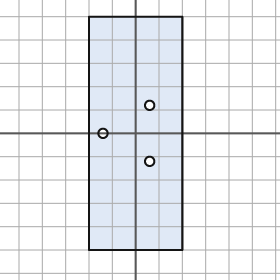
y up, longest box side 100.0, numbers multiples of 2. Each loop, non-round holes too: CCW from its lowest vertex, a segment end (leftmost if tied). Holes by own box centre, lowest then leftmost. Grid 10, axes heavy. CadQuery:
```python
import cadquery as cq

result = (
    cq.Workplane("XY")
    .moveTo(-20.0, -50.0)
    .lineTo(20.0, -50.0)
    .lineTo(20.0, 50.0)
    .lineTo(-20.0, 50.0)
    .close()
    .moveTo(6.0, -12.0)
    .circle(2.0)
    .moveTo(-14.0, 0.0)
    .circle(2.0)
    .moveTo(6.0, 12.0)
    .circle(2.0)
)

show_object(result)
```